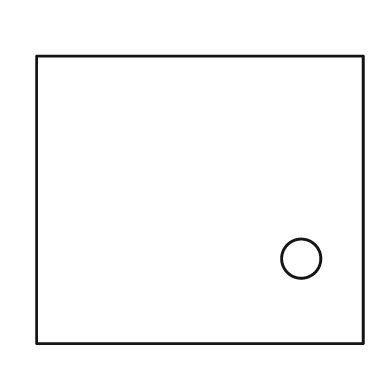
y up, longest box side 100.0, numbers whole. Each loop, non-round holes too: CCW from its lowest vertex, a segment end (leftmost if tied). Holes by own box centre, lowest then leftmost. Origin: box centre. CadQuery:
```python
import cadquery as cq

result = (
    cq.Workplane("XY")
    .moveTo(-50.0, -44.0)
    .lineTo(50.0, -44.0)
    .lineTo(50.0, 44.0)
    .lineTo(-50.0, 44.0)
    .close()
    .moveTo(31.0, -18.0)
    .circle(6.0)
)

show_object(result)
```